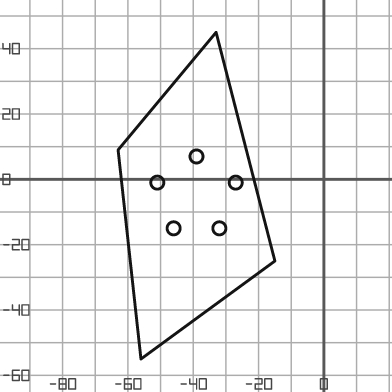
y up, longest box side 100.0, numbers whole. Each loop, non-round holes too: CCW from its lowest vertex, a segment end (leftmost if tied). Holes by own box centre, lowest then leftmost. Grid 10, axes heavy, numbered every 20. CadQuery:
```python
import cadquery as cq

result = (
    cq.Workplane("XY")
    .moveTo(-56.0, -55.0)
    .lineTo(-15.0, -25.0)
    .lineTo(-33.0, 45.0)
    .lineTo(-63.0, 9.0)
    .close()
    .moveTo(-46.0, -15.0)
    .circle(2.0)
    .moveTo(-32.0, -15.0)
    .circle(2.0)
    .moveTo(-51.0, -1.0)
    .circle(2.0)
    .moveTo(-27.0, -1.0)
    .circle(2.0)
    .moveTo(-39.0, 7.0)
    .circle(2.0)
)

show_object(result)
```